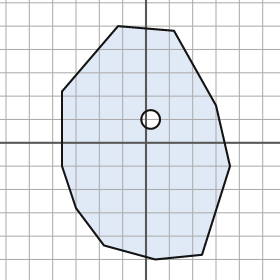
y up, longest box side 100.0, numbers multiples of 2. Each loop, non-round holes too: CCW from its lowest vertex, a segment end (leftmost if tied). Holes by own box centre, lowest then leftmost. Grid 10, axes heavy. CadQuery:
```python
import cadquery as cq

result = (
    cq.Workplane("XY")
    .moveTo(4.0, -50.0)
    .lineTo(24.0, -48.0)
    .lineTo(36.0, -10.0)
    .lineTo(30.0, 16.0)
    .lineTo(12.0, 48.0)
    .lineTo(-12.0, 50.0)
    .lineTo(-36.0, 22.0)
    .lineTo(-36.0, -10.0)
    .lineTo(-30.0, -28.0)
    .lineTo(-18.0, -44.0)
    .close()
    .moveTo(2.0, 10.0)
    .circle(4.0)
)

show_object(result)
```